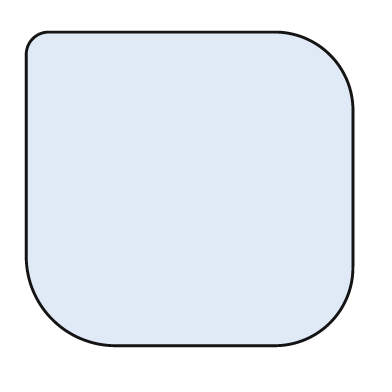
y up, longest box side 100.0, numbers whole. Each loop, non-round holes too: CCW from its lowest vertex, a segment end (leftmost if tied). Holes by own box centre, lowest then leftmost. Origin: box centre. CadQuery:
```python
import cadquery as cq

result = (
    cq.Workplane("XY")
    .moveTo(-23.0, -48.0)
    .lineTo(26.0, -48.0)
    .threePointArc((43.0, -41.0), (50.0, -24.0))
    .lineTo(50.0, 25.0)
    .threePointArc((43.0, 41.0), (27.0, 48.0))
    .lineTo(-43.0, 48.0)
    .threePointArc((-48.0, 46.0), (-50.0, 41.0))
    .lineTo(-50.0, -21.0)
    .threePointArc((-42.0, -40.0), (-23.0, -48.0))
    .close()
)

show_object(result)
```